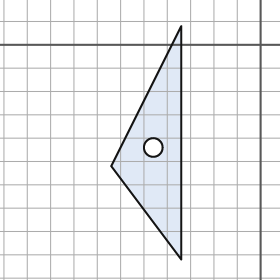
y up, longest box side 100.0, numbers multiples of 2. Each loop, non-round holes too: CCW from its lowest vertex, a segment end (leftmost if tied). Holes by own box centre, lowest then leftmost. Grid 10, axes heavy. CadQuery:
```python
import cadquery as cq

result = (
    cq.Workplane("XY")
    .moveTo(-34.0, -92.0)
    .lineTo(-34.0, 8.0)
    .lineTo(-64.0, -52.0)
    .close()
    .moveTo(-46.0, -44.0)
    .circle(4.0)
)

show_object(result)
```